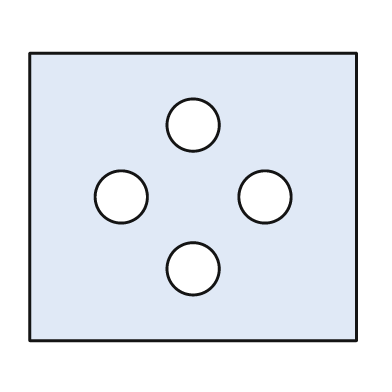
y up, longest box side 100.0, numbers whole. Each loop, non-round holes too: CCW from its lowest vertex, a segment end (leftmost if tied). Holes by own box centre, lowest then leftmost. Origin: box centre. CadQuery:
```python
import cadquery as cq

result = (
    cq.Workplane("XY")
    .moveTo(-50.0, -44.0)
    .lineTo(50.0, -44.0)
    .lineTo(50.0, 44.0)
    .lineTo(-50.0, 44.0)
    .close()
    .moveTo(0.0, -22.0)
    .circle(8.0)
    .moveTo(-22.0, 0.0)
    .circle(8.0)
    .moveTo(22.0, 0.0)
    .circle(8.0)
    .moveTo(0.0, 22.0)
    .circle(8.0)
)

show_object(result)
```